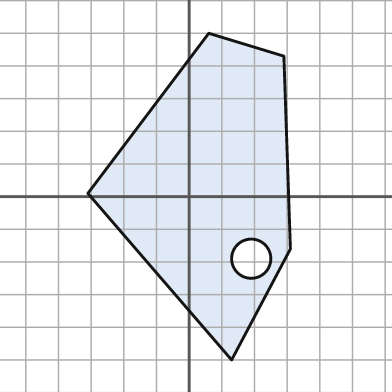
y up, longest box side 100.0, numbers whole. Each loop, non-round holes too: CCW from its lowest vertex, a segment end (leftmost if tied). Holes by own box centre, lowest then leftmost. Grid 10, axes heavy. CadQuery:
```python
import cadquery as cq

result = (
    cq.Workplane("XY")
    .moveTo(13.0, -50.0)
    .lineTo(31.0, -16.0)
    .lineTo(29.0, 43.0)
    .lineTo(6.0, 50.0)
    .lineTo(-31.0, 1.0)
    .close()
    .moveTo(19.0, -19.0)
    .circle(6.0)
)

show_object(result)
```